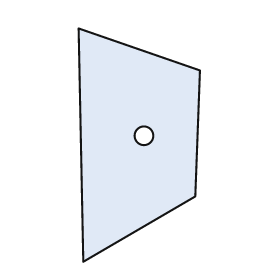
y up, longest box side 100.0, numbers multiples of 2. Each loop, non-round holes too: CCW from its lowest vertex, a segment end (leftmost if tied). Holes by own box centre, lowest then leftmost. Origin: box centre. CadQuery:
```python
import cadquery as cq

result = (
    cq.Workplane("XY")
    .moveTo(-24.0, -50.0)
    .lineTo(24.0, -22.0)
    .lineTo(26.0, 32.0)
    .lineTo(-26.0, 50.0)
    .close()
    .moveTo(2.0, 4.0)
    .circle(4.0)
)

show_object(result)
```